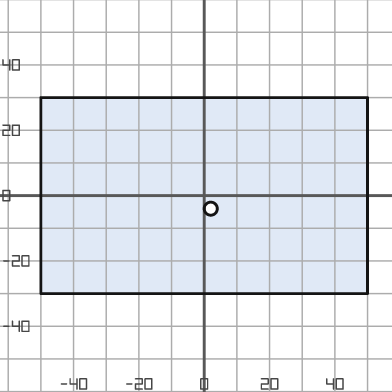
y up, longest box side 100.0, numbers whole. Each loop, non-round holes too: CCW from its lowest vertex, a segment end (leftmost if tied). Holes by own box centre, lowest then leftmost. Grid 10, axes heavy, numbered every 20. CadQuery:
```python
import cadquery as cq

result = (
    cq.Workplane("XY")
    .moveTo(-50.0, -30.0)
    .lineTo(50.0, -30.0)
    .lineTo(50.0, 30.0)
    .lineTo(-50.0, 30.0)
    .close()
    .moveTo(2.0, -4.0)
    .circle(2.0)
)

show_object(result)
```